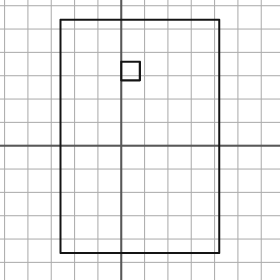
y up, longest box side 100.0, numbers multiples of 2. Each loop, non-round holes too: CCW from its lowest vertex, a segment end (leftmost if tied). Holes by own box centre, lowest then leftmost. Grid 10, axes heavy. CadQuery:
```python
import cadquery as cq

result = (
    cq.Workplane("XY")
    .moveTo(-26.0, -46.0)
    .lineTo(42.0, -46.0)
    .lineTo(42.0, 54.0)
    .lineTo(-26.0, 54.0)
    .close()
    .moveTo(0.0, 28.0)
    .lineTo(8.0, 28.0)
    .lineTo(8.0, 36.0)
    .lineTo(0.0, 36.0)
    .close()
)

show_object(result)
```